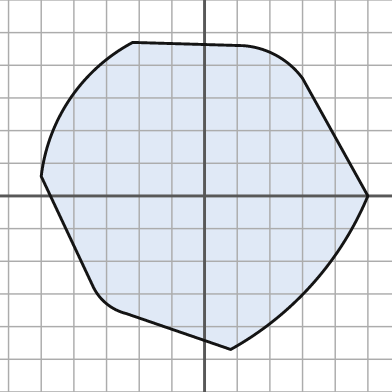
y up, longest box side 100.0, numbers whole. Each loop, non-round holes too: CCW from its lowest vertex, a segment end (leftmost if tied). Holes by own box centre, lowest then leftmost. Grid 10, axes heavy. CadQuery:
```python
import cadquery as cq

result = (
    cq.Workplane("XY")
    .moveTo(8.0, -47.0)
    .threePointArc((33.0, -27.0), (50.0, 0.0))
    .lineTo(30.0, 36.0)
    .threePointArc((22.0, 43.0), (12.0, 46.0))
    .lineTo(-22.0, 47.0)
    .threePointArc((-41.0, 30.0), (-50.0, 6.0))
    .lineTo(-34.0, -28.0)
    .threePointArc((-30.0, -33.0), (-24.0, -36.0))
    .close()
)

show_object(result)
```